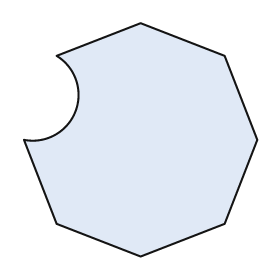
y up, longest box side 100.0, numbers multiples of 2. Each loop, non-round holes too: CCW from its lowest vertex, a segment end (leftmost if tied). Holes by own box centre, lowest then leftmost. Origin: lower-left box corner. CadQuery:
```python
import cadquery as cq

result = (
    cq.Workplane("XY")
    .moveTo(50.0, 0.0)
    .lineTo(86.0, 14.0)
    .lineTo(100.0, 50.0)
    .lineTo(86.0, 86.0)
    .lineTo(50.0, 100.0)
    .lineTo(14.0, 86.0)
    .threePointArc((22.0, 62.0), (0.0, 50.0))
    .lineTo(14.0, 14.0)
    .close()
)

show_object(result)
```